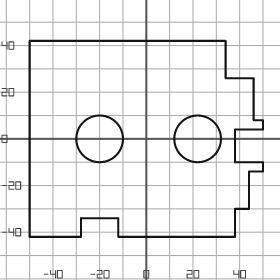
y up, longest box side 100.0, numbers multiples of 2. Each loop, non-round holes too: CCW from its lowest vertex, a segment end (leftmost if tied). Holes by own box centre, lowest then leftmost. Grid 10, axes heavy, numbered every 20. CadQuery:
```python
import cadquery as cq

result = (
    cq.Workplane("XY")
    .moveTo(-50.0, -42.0)
    .lineTo(-28.0, -42.0)
    .lineTo(-28.0, -34.0)
    .lineTo(-12.0, -34.0)
    .lineTo(-12.0, -42.0)
    .lineTo(38.0, -42.0)
    .lineTo(38.0, -30.0)
    .lineTo(44.0, -30.0)
    .lineTo(44.0, -14.0)
    .lineTo(50.0, -14.0)
    .lineTo(50.0, -10.0)
    .lineTo(38.0, -10.0)
    .lineTo(38.0, 4.0)
    .lineTo(50.0, 4.0)
    .lineTo(50.0, 8.0)
    .lineTo(46.0, 8.0)
    .lineTo(46.0, 26.0)
    .lineTo(34.0, 26.0)
    .lineTo(34.0, 42.0)
    .lineTo(-50.0, 42.0)
    .close()
    .moveTo(-20.0, 0.0)
    .circle(10.0)
    .moveTo(22.0, 0.0)
    .circle(10.0)
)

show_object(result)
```